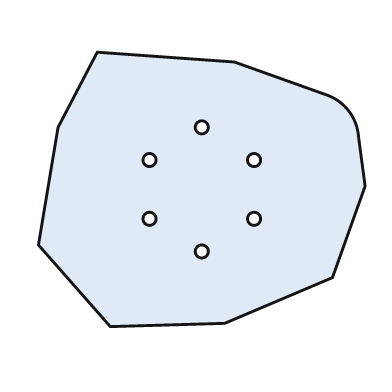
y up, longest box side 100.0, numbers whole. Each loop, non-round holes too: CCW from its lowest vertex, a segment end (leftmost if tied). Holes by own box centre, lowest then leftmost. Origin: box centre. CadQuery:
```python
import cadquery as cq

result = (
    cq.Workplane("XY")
    .moveTo(-28.0, -42.0)
    .lineTo(7.0, -41.0)
    .lineTo(40.0, -27.0)
    .lineTo(50.0, 1.0)
    .lineTo(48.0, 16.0)
    .threePointArc((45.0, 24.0), (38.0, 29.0))
    .lineTo(10.0, 39.0)
    .lineTo(-32.0, 42.0)
    .lineTo(-44.0, 19.0)
    .lineTo(-50.0, -17.0)
    .close()
    .moveTo(0.0, -19.0)
    .circle(2.0)
    .moveTo(-16.0, -9.0)
    .circle(2.0)
    .moveTo(16.0, -9.0)
    .circle(2.0)
    .moveTo(-16.0, 9.0)
    .circle(2.0)
    .moveTo(16.0, 9.0)
    .circle(2.0)
    .moveTo(0.0, 19.0)
    .circle(2.0)
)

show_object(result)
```